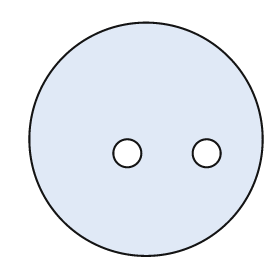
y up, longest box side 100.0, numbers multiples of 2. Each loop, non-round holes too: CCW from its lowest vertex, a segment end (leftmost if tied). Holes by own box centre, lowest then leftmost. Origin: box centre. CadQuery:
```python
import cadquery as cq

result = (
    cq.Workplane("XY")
    .moveTo(0.0, 0.0)
    .circle(50.0)
    .moveTo(-8.0, -6.0)
    .circle(6.0)
    .moveTo(26.0, -6.0)
    .circle(6.0)
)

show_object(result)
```